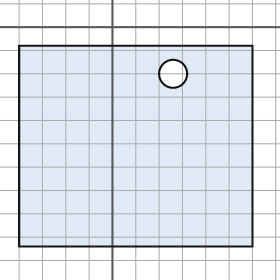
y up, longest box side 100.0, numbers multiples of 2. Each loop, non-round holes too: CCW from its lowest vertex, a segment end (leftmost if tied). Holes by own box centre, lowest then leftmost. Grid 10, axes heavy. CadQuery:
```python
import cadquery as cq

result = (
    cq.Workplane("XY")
    .moveTo(-40.0, -94.0)
    .lineTo(60.0, -94.0)
    .lineTo(60.0, -8.0)
    .lineTo(-40.0, -8.0)
    .close()
    .moveTo(26.0, -20.0)
    .circle(6.0)
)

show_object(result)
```